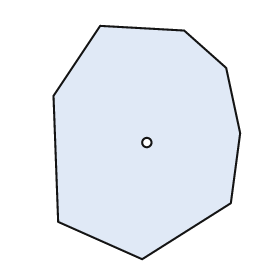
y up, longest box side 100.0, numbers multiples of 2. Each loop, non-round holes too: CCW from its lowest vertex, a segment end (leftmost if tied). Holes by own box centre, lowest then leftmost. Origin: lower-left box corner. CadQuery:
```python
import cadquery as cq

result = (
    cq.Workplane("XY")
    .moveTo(38.0, 0.0)
    .lineTo(76.0, 24.0)
    .lineTo(80.0, 54.0)
    .lineTo(74.0, 82.0)
    .lineTo(56.0, 98.0)
    .lineTo(20.0, 100.0)
    .lineTo(0.0, 70.0)
    .lineTo(2.0, 16.0)
    .close()
    .moveTo(40.0, 50.0)
    .circle(2.0)
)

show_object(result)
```